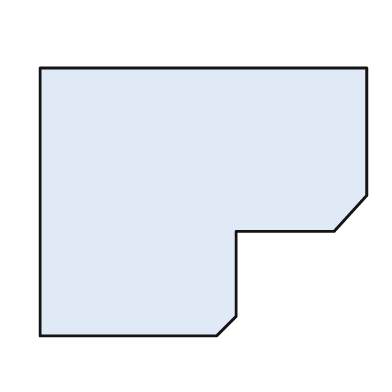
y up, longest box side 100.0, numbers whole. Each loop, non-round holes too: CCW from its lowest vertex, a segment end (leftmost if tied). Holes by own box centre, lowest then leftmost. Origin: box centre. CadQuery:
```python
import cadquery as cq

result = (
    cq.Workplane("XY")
    .moveTo(-50.0, -41.0)
    .lineTo(4.0, -41.0)
    .lineTo(10.0, -35.0)
    .lineTo(10.0, -9.0)
    .lineTo(40.0, -9.0)
    .lineTo(50.0, 2.0)
    .lineTo(50.0, 41.0)
    .lineTo(-50.0, 41.0)
    .close()
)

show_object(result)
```